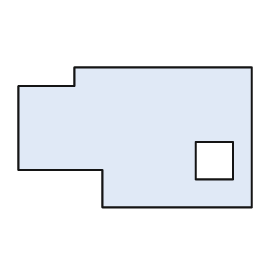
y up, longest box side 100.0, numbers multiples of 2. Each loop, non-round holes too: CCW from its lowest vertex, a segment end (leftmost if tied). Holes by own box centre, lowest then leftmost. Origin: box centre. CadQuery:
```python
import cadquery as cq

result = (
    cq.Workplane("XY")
    .moveTo(-14.0, -30.0)
    .lineTo(50.0, -30.0)
    .lineTo(50.0, 30.0)
    .lineTo(-26.0, 30.0)
    .lineTo(-26.0, 22.0)
    .lineTo(-50.0, 22.0)
    .lineTo(-50.0, -14.0)
    .lineTo(-14.0, -14.0)
    .close()
    .moveTo(26.0, -18.0)
    .lineTo(42.0, -18.0)
    .lineTo(42.0, -2.0)
    .lineTo(26.0, -2.0)
    .close()
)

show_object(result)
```